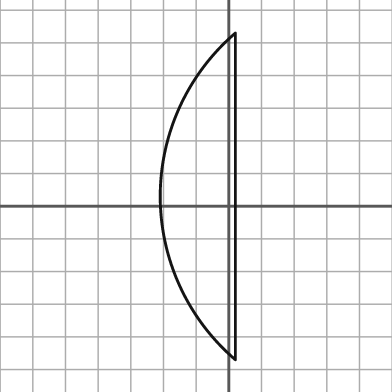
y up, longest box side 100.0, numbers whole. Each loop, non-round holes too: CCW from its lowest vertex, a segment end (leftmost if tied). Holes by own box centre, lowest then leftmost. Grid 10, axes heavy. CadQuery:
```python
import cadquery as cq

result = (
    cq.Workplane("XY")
    .moveTo(2.0, -47.0)
    .lineTo(2.0, 53.0)
    .threePointArc((-21.0, 3.0), (2.0, -47.0))
    .close()
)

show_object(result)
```